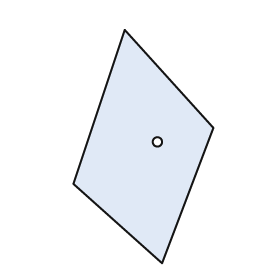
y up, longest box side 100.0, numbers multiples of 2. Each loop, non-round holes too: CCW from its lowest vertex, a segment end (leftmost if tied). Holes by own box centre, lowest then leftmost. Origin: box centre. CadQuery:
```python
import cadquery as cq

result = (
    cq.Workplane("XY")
    .moveTo(8.0, -50.0)
    .lineTo(30.0, 8.0)
    .lineTo(-8.0, 50.0)
    .lineTo(-30.0, -16.0)
    .close()
    .moveTo(6.0, 2.0)
    .circle(2.0)
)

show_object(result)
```